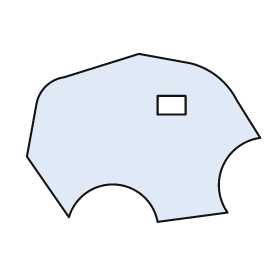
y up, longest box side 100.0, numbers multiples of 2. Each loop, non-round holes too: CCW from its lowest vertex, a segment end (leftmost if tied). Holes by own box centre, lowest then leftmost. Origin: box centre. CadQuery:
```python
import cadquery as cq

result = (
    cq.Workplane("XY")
    .moveTo(6.0, -36.0)
    .lineTo(36.0, -32.0)
    .threePointArc((34.0, -12.0), (50.0, 0.0))
    .lineTo(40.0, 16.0)
    .threePointArc((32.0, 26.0), (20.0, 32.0))
    .lineTo(-2.0, 36.0)
    .lineTo(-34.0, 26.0)
    .threePointArc((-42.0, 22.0), (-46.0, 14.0))
    .lineTo(-50.0, -8.0)
    .lineTo(-32.0, -34.0)
    .threePointArc((-12.0, -20.0), (6.0, -36.0))
    .close()
    .moveTo(6.0, 10.0)
    .lineTo(18.0, 10.0)
    .lineTo(18.0, 18.0)
    .lineTo(6.0, 18.0)
    .close()
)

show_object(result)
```